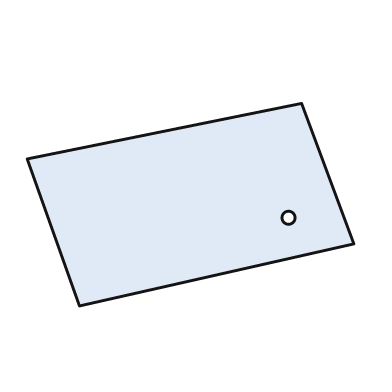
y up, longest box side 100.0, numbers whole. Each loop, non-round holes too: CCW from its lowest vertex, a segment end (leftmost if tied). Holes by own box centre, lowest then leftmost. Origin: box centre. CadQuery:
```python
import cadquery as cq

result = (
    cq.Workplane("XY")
    .moveTo(-34.0, -31.0)
    .lineTo(50.0, -12.0)
    .lineTo(34.0, 31.0)
    .lineTo(-50.0, 14.0)
    .close()
    .moveTo(30.0, -4.0)
    .circle(2.0)
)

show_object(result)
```